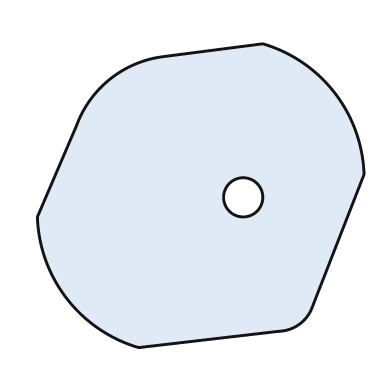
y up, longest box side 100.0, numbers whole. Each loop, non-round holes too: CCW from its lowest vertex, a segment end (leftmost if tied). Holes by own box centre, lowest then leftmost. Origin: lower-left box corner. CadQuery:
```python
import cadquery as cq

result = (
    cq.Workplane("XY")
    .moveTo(31.0, 0.0)
    .lineTo(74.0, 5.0)
    .threePointArc((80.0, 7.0), (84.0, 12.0))
    .lineTo(100.0, 53.0)
    .threePointArc((91.0, 78.0), (69.0, 93.0))
    .lineTo(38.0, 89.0)
    .threePointArc((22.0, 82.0), (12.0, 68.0))
    .lineTo(0.0, 40.0)
    .threePointArc((9.0, 15.0), (31.0, 0.0))
    .close()
    .moveTo(63.0, 46.0)
    .circle(6.0)
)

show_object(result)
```